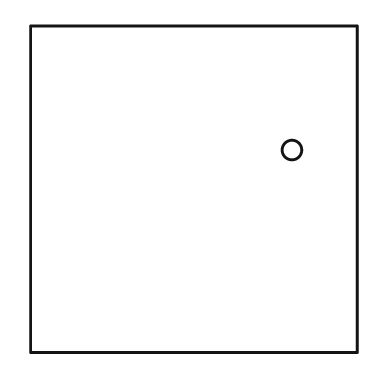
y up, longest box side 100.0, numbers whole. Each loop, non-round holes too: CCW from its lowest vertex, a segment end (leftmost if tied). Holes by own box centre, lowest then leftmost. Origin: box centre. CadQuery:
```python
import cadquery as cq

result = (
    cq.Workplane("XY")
    .moveTo(-50.0, -50.0)
    .lineTo(50.0, -50.0)
    .lineTo(50.0, 50.0)
    .lineTo(-50.0, 50.0)
    .close()
    .moveTo(30.0, 12.0)
    .circle(3.0)
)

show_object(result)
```